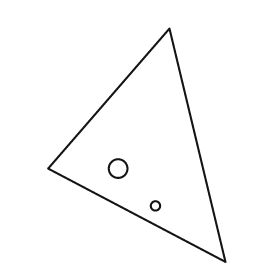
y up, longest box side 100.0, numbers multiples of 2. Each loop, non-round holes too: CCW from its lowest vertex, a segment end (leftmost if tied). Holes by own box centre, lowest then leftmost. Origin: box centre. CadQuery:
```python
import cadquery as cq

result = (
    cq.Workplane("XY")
    .moveTo(38.0, -50.0)
    .lineTo(14.0, 50.0)
    .lineTo(-38.0, -10.0)
    .close()
    .moveTo(8.0, -26.0)
    .circle(2.0)
    .moveTo(-8.0, -10.0)
    .circle(4.0)
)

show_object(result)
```